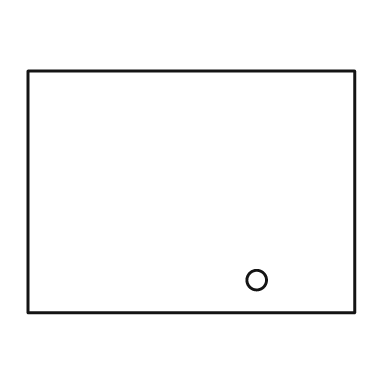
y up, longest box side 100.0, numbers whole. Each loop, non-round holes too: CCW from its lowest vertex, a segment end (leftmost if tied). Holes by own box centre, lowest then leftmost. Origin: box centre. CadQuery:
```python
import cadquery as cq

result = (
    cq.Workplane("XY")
    .moveTo(-50.0, -37.0)
    .lineTo(50.0, -37.0)
    .lineTo(50.0, 37.0)
    .lineTo(-50.0, 37.0)
    .close()
    .moveTo(20.0, -27.0)
    .circle(3.0)
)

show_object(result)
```